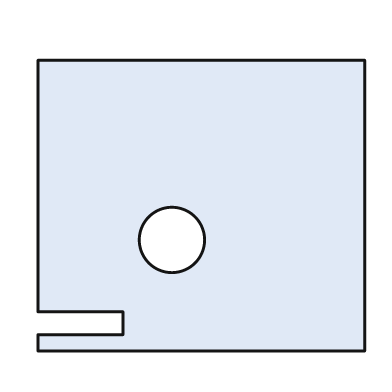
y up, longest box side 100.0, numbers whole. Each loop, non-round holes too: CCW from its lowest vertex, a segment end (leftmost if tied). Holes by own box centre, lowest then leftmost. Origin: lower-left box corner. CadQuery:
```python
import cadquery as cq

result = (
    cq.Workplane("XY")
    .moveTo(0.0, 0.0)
    .lineTo(100.0, 0.0)
    .lineTo(100.0, 89.0)
    .lineTo(0.0, 89.0)
    .lineTo(0.0, 12.0)
    .lineTo(26.0, 12.0)
    .lineTo(26.0, 5.0)
    .lineTo(0.0, 5.0)
    .close()
    .moveTo(41.0, 34.0)
    .circle(10.0)
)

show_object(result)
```